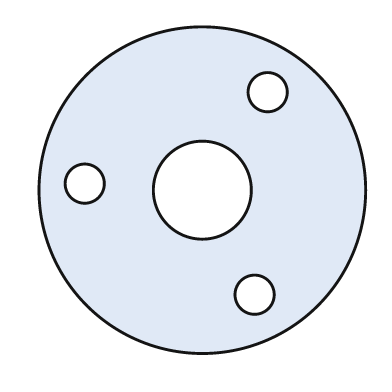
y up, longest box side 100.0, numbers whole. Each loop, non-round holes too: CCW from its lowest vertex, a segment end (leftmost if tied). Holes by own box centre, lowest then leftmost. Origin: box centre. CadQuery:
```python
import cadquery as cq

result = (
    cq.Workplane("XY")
    .moveTo(0.0, 0.0)
    .circle(50.0)
    .moveTo(16.0, -32.0)
    .circle(6.0)
    .moveTo(0.0, 0.0)
    .circle(15.0)
    .moveTo(-36.0, 2.0)
    .circle(6.0)
    .moveTo(20.0, 30.0)
    .circle(6.0)
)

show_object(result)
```